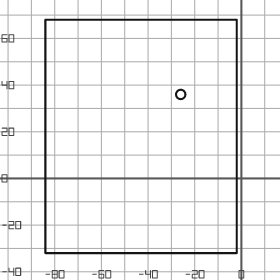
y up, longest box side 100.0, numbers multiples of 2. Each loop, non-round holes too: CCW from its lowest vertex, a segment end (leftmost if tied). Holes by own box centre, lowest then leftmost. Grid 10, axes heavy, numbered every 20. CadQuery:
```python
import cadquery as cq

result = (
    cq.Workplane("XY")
    .moveTo(-84.0, -32.0)
    .lineTo(-2.0, -32.0)
    .lineTo(-2.0, 68.0)
    .lineTo(-84.0, 68.0)
    .close()
    .moveTo(-26.0, 36.0)
    .circle(2.0)
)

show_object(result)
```